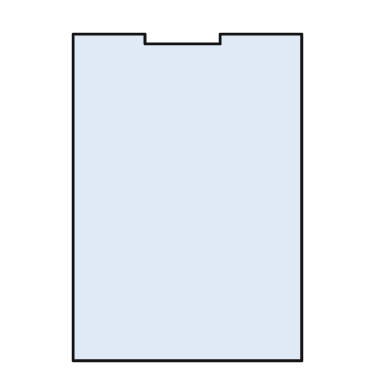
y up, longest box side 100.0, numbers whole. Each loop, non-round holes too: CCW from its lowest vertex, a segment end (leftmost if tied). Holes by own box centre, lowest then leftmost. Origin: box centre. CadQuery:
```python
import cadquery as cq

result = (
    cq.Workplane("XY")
    .moveTo(-35.0, -50.0)
    .lineTo(35.0, -50.0)
    .lineTo(35.0, 50.0)
    .lineTo(10.0, 50.0)
    .lineTo(10.0, 47.0)
    .lineTo(-13.0, 47.0)
    .lineTo(-13.0, 50.0)
    .lineTo(-35.0, 50.0)
    .close()
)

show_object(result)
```